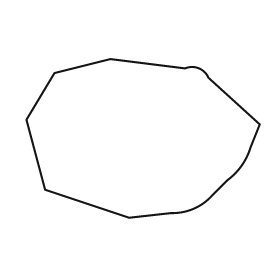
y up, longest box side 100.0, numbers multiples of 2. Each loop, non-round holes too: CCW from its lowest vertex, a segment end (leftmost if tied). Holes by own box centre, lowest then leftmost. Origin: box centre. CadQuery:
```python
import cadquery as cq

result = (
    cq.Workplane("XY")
    .moveTo(-6.0, -34.0)
    .lineTo(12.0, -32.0)
    .threePointArc((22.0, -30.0), (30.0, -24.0))
    .lineTo(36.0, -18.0)
    .threePointArc((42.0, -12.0), (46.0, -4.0))
    .lineTo(50.0, 6.0)
    .lineTo(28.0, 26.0)
    .threePointArc((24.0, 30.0), (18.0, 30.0))
    .lineTo(-14.0, 34.0)
    .lineTo(-38.0, 28.0)
    .lineTo(-50.0, 8.0)
    .lineTo(-42.0, -22.0)
    .close()
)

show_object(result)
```